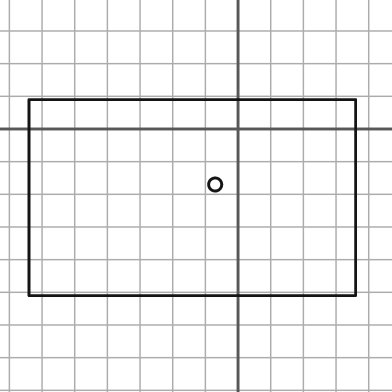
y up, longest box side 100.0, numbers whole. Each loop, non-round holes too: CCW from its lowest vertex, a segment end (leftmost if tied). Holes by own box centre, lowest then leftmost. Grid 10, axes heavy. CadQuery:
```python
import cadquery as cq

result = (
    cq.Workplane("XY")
    .moveTo(-64.0, -51.0)
    .lineTo(36.0, -51.0)
    .lineTo(36.0, 9.0)
    .lineTo(-64.0, 9.0)
    .close()
    .moveTo(-7.0, -17.0)
    .circle(2.0)
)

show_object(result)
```